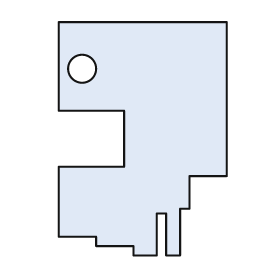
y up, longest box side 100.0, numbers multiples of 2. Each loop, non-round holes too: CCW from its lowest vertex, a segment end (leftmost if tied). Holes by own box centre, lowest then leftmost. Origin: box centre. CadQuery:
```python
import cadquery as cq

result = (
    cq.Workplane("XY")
    .moveTo(-4.0, -50.0)
    .lineTo(6.0, -50.0)
    .lineTo(6.0, -32.0)
    .lineTo(10.0, -32.0)
    .lineTo(10.0, -50.0)
    .lineTo(16.0, -50.0)
    .lineTo(16.0, -30.0)
    .lineTo(20.0, -30.0)
    .lineTo(20.0, -16.0)
    .lineTo(36.0, -16.0)
    .lineTo(36.0, 50.0)
    .lineTo(-36.0, 50.0)
    .lineTo(-36.0, 12.0)
    .lineTo(-8.0, 12.0)
    .lineTo(-8.0, -12.0)
    .lineTo(-36.0, -12.0)
    .lineTo(-36.0, -42.0)
    .lineTo(-20.0, -42.0)
    .lineTo(-20.0, -46.0)
    .lineTo(-4.0, -46.0)
    .close()
    .moveTo(-26.0, 30.0)
    .circle(6.0)
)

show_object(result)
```